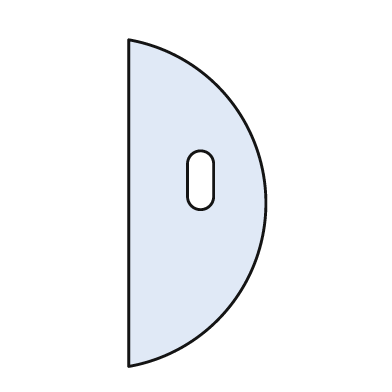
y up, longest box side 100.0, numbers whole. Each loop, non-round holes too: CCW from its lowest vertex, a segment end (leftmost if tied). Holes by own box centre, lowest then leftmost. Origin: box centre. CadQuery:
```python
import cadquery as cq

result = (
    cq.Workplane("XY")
    .moveTo(-21.0, -50.0)
    .threePointArc((21.0, 0.0), (-21.0, 50.0))
    .close()
    .moveTo(-3.0, 2.0)
    .threePointArc((1.0, -2.0), (5.0, 2.0))
    .lineTo(5.0, 12.0)
    .threePointArc((1.0, 16.0), (-3.0, 12.0))
    .close()
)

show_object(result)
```